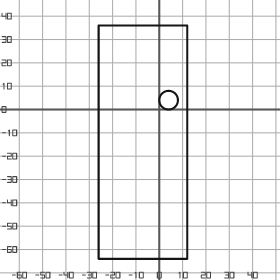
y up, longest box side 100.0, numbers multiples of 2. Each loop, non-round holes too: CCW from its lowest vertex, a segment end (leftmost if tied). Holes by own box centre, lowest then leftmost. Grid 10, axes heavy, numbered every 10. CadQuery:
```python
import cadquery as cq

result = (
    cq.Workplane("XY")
    .moveTo(-26.0, -64.0)
    .lineTo(12.0, -64.0)
    .lineTo(12.0, 36.0)
    .lineTo(-26.0, 36.0)
    .close()
    .moveTo(4.0, 4.0)
    .circle(4.0)
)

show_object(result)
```